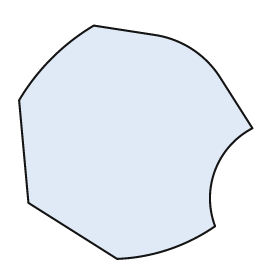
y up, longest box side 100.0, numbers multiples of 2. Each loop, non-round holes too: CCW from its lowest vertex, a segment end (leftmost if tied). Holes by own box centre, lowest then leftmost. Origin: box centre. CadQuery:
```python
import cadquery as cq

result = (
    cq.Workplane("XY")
    .moveTo(-8.0, -50.0)
    .threePointArc((14.0, -46.0), (34.0, -36.0))
    .threePointArc((34.0, -12.0), (50.0, 6.0))
    .lineTo(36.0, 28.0)
    .threePointArc((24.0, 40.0), (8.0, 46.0))
    .lineTo(-18.0, 50.0)
    .threePointArc((-36.0, 36.0), (-50.0, 18.0))
    .lineTo(-46.0, -26.0)
    .close()
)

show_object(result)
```